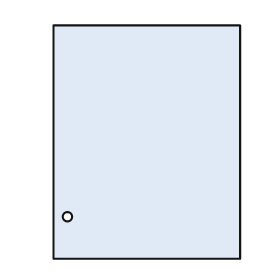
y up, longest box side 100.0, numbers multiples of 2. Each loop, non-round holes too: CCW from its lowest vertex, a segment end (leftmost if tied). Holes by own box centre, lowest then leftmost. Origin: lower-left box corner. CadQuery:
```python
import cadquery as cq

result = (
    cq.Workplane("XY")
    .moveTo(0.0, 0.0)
    .lineTo(80.0, 0.0)
    .lineTo(80.0, 100.0)
    .lineTo(0.0, 100.0)
    .close()
    .moveTo(6.0, 18.0)
    .circle(2.0)
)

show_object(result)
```